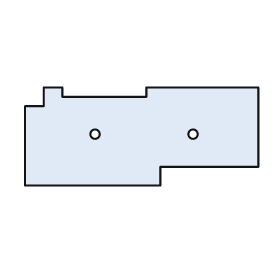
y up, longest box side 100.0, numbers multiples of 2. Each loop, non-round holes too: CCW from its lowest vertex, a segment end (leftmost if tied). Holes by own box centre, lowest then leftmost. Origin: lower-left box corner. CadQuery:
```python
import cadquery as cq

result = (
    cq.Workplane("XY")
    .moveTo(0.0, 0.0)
    .lineTo(58.0, 0.0)
    .lineTo(58.0, 8.0)
    .lineTo(100.0, 8.0)
    .lineTo(100.0, 42.0)
    .lineTo(52.0, 42.0)
    .lineTo(52.0, 38.0)
    .lineTo(16.0, 38.0)
    .lineTo(16.0, 42.0)
    .lineTo(8.0, 42.0)
    .lineTo(8.0, 34.0)
    .lineTo(0.0, 34.0)
    .close()
    .moveTo(30.0, 22.0)
    .circle(2.0)
    .moveTo(72.0, 22.0)
    .circle(2.0)
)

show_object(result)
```